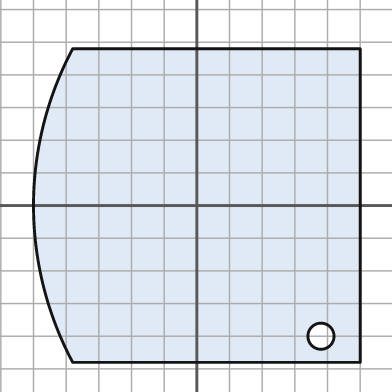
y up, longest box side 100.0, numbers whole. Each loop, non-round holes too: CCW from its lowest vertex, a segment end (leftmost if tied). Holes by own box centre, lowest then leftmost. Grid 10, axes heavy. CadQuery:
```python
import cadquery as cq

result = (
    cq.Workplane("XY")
    .moveTo(-38.0, -48.0)
    .lineTo(50.0, -48.0)
    .lineTo(50.0, 48.0)
    .lineTo(-38.0, 48.0)
    .threePointArc((-50.0, 0.0), (-38.0, -48.0))
    .close()
    .moveTo(38.0, -40.0)
    .circle(4.0)
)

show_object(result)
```